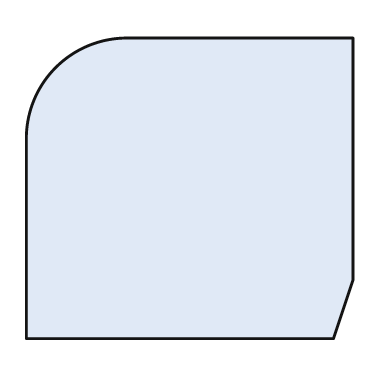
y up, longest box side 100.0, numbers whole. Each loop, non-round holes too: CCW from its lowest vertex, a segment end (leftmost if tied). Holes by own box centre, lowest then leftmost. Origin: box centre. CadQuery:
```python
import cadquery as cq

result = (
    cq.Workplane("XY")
    .moveTo(-50.0, -46.0)
    .lineTo(44.0, -46.0)
    .lineTo(50.0, -28.0)
    .lineTo(50.0, 46.0)
    .lineTo(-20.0, 46.0)
    .threePointArc((-41.0, 37.0), (-50.0, 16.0))
    .close()
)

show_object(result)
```